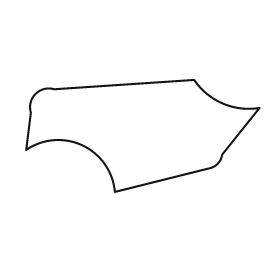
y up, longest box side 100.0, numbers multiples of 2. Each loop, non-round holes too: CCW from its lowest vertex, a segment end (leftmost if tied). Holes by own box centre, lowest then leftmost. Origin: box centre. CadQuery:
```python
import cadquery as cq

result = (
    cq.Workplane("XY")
    .moveTo(-12.0, -24.0)
    .lineTo(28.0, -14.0)
    .threePointArc((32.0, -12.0), (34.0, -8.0))
    .lineTo(50.0, 12.0)
    .threePointArc((34.0, 14.0), (22.0, 24.0))
    .lineTo(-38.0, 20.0)
    .threePointArc((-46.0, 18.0), (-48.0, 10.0))
    .lineTo(-50.0, -6.0)
    .threePointArc((-26.0, -4.0), (-12.0, -24.0))
    .close()
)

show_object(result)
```